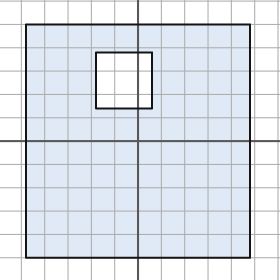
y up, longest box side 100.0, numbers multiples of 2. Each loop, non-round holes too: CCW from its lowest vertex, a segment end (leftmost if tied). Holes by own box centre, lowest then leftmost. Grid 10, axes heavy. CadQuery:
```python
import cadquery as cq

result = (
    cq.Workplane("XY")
    .moveTo(-48.0, -50.0)
    .lineTo(48.0, -50.0)
    .lineTo(48.0, 50.0)
    .lineTo(-48.0, 50.0)
    .close()
    .moveTo(-18.0, 14.0)
    .lineTo(6.0, 14.0)
    .lineTo(6.0, 38.0)
    .lineTo(-18.0, 38.0)
    .close()
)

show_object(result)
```